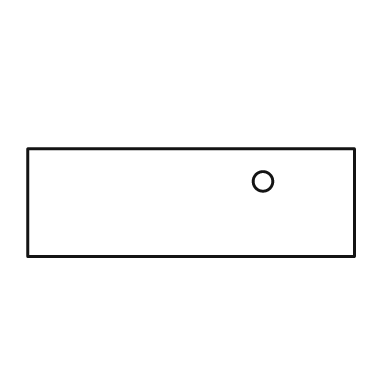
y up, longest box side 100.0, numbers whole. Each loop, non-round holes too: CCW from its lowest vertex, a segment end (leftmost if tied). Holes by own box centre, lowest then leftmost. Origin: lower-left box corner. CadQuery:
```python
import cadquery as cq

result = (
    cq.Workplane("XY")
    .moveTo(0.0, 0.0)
    .lineTo(100.0, 0.0)
    .lineTo(100.0, 33.0)
    .lineTo(0.0, 33.0)
    .close()
    .moveTo(72.0, 23.0)
    .circle(3.0)
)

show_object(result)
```